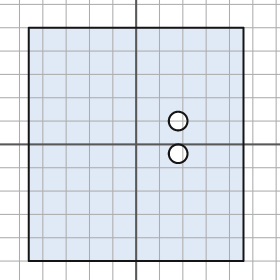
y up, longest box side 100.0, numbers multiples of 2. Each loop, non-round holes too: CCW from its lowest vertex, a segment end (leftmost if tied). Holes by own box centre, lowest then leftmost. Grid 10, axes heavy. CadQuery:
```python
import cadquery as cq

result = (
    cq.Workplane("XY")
    .moveTo(-46.0, -50.0)
    .lineTo(46.0, -50.0)
    .lineTo(46.0, 50.0)
    .lineTo(-46.0, 50.0)
    .close()
    .moveTo(18.0, -4.0)
    .circle(4.0)
    .moveTo(18.0, 10.0)
    .circle(4.0)
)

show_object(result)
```